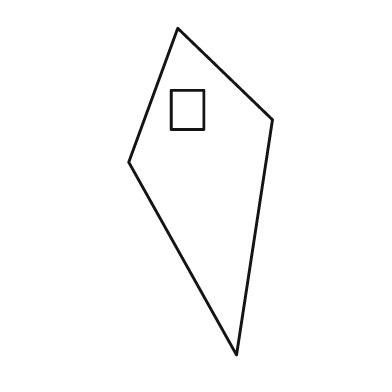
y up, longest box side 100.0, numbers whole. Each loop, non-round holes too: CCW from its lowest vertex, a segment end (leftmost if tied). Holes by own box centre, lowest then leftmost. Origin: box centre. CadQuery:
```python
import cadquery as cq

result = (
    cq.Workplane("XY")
    .moveTo(11.0, -50.0)
    .lineTo(22.0, 22.0)
    .lineTo(-7.0, 50.0)
    .lineTo(-22.0, 9.0)
    .close()
    .moveTo(-9.0, 19.0)
    .lineTo(1.0, 19.0)
    .lineTo(1.0, 31.0)
    .lineTo(-9.0, 31.0)
    .close()
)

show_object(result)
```